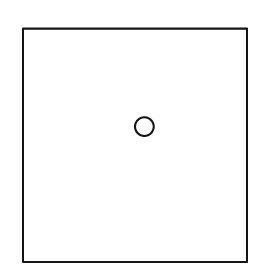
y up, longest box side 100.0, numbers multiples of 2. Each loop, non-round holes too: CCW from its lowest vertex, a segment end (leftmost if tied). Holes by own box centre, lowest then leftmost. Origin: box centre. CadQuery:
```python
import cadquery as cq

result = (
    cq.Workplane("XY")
    .moveTo(-48.0, -50.0)
    .lineTo(48.0, -50.0)
    .lineTo(48.0, 50.0)
    .lineTo(-48.0, 50.0)
    .close()
    .moveTo(4.0, 8.0)
    .circle(4.0)
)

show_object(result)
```